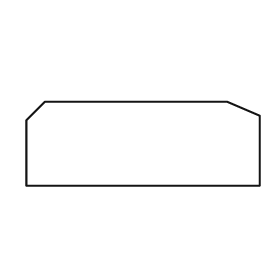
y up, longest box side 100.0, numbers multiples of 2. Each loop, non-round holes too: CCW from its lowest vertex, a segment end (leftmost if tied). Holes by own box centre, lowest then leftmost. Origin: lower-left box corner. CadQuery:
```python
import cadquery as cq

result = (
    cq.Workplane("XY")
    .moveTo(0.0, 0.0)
    .lineTo(100.0, 0.0)
    .lineTo(100.0, 30.0)
    .lineTo(86.0, 36.0)
    .lineTo(8.0, 36.0)
    .lineTo(0.0, 28.0)
    .close()
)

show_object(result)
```